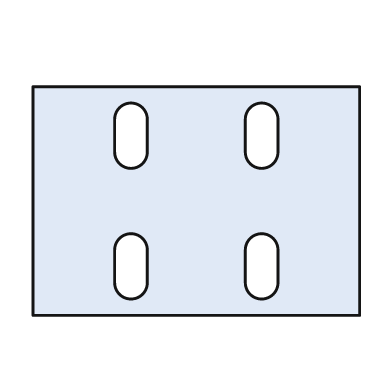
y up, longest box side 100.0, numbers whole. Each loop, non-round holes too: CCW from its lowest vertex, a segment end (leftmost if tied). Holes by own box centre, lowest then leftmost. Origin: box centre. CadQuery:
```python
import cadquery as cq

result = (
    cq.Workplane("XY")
    .moveTo(-50.0, -35.0)
    .lineTo(50.0, -35.0)
    .lineTo(50.0, 35.0)
    .lineTo(-50.0, 35.0)
    .close()
    .moveTo(-25.0, -25.0)
    .threePointArc((-20.0, -30.0), (-15.0, -25.0))
    .lineTo(-15.0, -15.0)
    .threePointArc((-20.0, -10.0), (-25.0, -15.0))
    .close()
    .moveTo(15.0, -25.0)
    .threePointArc((20.0, -30.0), (25.0, -25.0))
    .lineTo(25.0, -15.0)
    .threePointArc((20.0, -10.0), (15.0, -15.0))
    .close()
    .moveTo(-25.0, 15.0)
    .threePointArc((-20.0, 10.0), (-15.0, 15.0))
    .lineTo(-15.0, 25.0)
    .threePointArc((-20.0, 30.0), (-25.0, 25.0))
    .close()
    .moveTo(15.0, 15.0)
    .threePointArc((20.0, 10.0), (25.0, 15.0))
    .lineTo(25.0, 25.0)
    .threePointArc((20.0, 30.0), (15.0, 25.0))
    .close()
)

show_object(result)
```